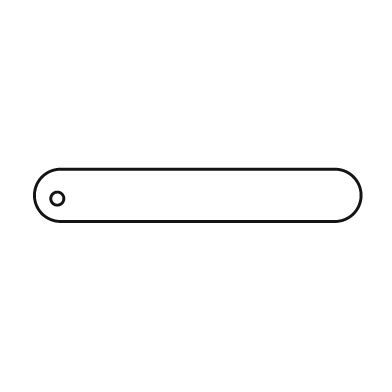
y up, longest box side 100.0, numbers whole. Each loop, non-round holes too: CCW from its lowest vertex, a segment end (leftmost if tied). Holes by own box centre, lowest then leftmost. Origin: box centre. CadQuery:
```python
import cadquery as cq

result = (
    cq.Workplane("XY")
    .moveTo(-42.0, -8.0)
    .lineTo(42.0, -8.0)
    .threePointArc((50.0, 0.0), (42.0, 8.0))
    .lineTo(-42.0, 8.0)
    .threePointArc((-50.0, 0.0), (-42.0, -8.0))
    .close()
    .moveTo(-43.0, -1.0)
    .circle(2.0)
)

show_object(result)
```